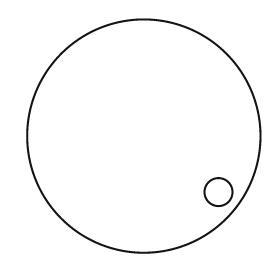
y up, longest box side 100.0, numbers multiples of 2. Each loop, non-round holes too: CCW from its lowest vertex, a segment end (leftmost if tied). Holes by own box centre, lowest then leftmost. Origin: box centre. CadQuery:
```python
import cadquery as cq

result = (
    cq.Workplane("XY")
    .moveTo(0.0, 0.0)
    .circle(50.0)
    .moveTo(32.0, -24.0)
    .circle(6.0)
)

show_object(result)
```